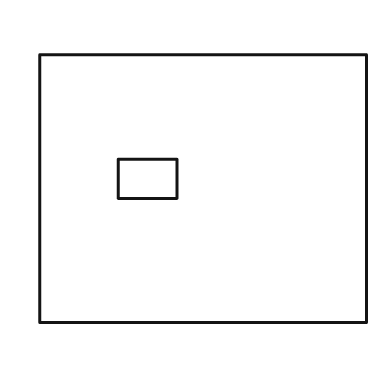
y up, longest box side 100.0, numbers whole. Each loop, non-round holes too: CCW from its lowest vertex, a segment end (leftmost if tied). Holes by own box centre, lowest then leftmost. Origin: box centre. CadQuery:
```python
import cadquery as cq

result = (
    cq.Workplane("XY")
    .moveTo(-50.0, -41.0)
    .lineTo(50.0, -41.0)
    .lineTo(50.0, 41.0)
    .lineTo(-50.0, 41.0)
    .close()
    .moveTo(-26.0, -3.0)
    .lineTo(-8.0, -3.0)
    .lineTo(-8.0, 9.0)
    .lineTo(-26.0, 9.0)
    .close()
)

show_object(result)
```